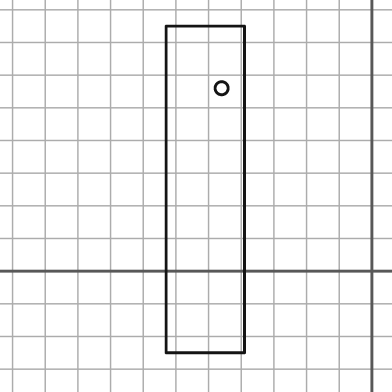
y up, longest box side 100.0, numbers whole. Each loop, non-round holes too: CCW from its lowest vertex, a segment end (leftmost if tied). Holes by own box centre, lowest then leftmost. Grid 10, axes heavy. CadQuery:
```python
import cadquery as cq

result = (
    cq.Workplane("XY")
    .moveTo(-63.0, -25.0)
    .lineTo(-39.0, -25.0)
    .lineTo(-39.0, 75.0)
    .lineTo(-63.0, 75.0)
    .close()
    .moveTo(-46.0, 56.0)
    .circle(2.0)
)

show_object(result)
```